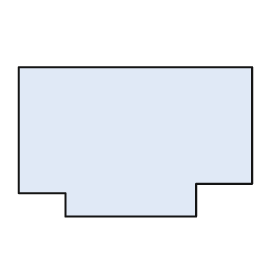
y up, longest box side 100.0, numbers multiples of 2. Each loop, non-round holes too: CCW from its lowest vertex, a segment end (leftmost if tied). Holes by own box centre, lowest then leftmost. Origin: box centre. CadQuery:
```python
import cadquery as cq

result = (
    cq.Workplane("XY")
    .moveTo(-30.0, -32.0)
    .lineTo(26.0, -32.0)
    .lineTo(26.0, -18.0)
    .lineTo(50.0, -18.0)
    .lineTo(50.0, 32.0)
    .lineTo(-50.0, 32.0)
    .lineTo(-50.0, -22.0)
    .lineTo(-30.0, -22.0)
    .close()
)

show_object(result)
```